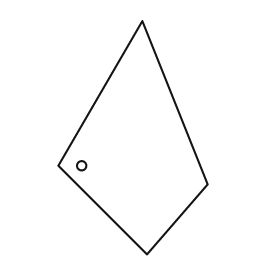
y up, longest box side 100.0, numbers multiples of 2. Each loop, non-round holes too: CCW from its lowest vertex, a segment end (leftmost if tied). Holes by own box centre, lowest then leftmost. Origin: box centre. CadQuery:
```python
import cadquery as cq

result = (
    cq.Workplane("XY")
    .moveTo(6.0, -50.0)
    .lineTo(32.0, -20.0)
    .lineTo(4.0, 50.0)
    .lineTo(-32.0, -12.0)
    .close()
    .moveTo(-22.0, -12.0)
    .circle(2.0)
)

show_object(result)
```